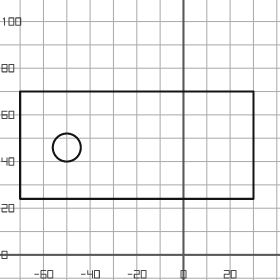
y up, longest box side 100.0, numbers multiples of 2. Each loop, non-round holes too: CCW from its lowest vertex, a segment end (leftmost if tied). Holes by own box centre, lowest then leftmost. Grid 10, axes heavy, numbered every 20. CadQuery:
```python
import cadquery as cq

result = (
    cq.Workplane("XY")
    .moveTo(-70.0, 24.0)
    .lineTo(30.0, 24.0)
    .lineTo(30.0, 70.0)
    .lineTo(-70.0, 70.0)
    .close()
    .moveTo(-50.0, 46.0)
    .circle(6.0)
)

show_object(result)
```